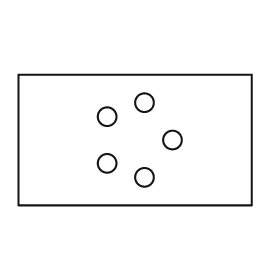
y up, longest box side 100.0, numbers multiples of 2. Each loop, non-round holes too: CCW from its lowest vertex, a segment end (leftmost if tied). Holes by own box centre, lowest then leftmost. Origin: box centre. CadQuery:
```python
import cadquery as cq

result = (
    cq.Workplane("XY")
    .moveTo(-50.0, -28.0)
    .lineTo(50.0, -28.0)
    .lineTo(50.0, 28.0)
    .lineTo(-50.0, 28.0)
    .close()
    .moveTo(4.0, -16.0)
    .circle(4.0)
    .moveTo(-12.0, -10.0)
    .circle(4.0)
    .moveTo(16.0, 0.0)
    .circle(4.0)
    .moveTo(-12.0, 10.0)
    .circle(4.0)
    .moveTo(4.0, 16.0)
    .circle(4.0)
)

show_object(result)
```